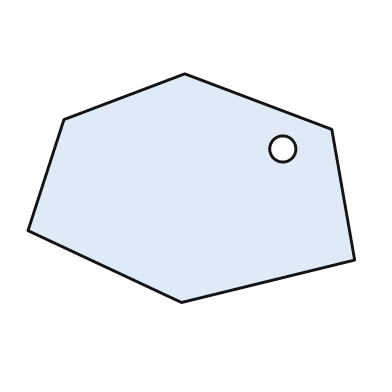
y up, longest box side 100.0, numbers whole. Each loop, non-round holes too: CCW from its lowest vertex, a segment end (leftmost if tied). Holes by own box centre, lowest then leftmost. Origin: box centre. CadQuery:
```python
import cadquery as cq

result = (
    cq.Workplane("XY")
    .moveTo(-3.0, -35.0)
    .lineTo(50.0, -22.0)
    .lineTo(43.0, 18.0)
    .lineTo(-2.0, 35.0)
    .lineTo(-39.0, 21.0)
    .lineTo(-50.0, -13.0)
    .close()
    .moveTo(28.0, 12.0)
    .circle(4.0)
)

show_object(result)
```